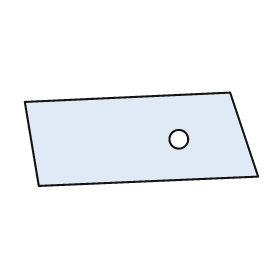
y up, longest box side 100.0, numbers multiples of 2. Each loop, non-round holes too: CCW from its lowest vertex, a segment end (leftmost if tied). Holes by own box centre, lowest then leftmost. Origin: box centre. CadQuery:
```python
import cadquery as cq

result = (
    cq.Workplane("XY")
    .moveTo(-44.0, -20.0)
    .lineTo(50.0, -16.0)
    .lineTo(38.0, 20.0)
    .lineTo(-50.0, 16.0)
    .close()
    .moveTo(16.0, 0.0)
    .circle(4.0)
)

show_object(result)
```